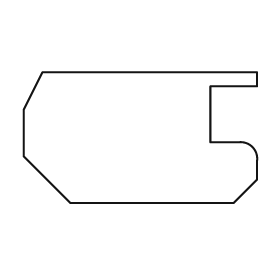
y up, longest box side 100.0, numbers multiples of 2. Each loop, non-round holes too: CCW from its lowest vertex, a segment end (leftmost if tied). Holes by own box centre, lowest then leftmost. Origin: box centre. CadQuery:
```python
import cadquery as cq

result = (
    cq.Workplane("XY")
    .moveTo(-30.0, -28.0)
    .lineTo(40.0, -28.0)
    .lineTo(50.0, -18.0)
    .lineTo(50.0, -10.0)
    .threePointArc((48.0, -4.0), (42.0, -2.0))
    .lineTo(30.0, -2.0)
    .lineTo(30.0, 22.0)
    .lineTo(50.0, 22.0)
    .lineTo(50.0, 28.0)
    .lineTo(-42.0, 28.0)
    .lineTo(-50.0, 12.0)
    .lineTo(-50.0, -8.0)
    .close()
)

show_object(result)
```